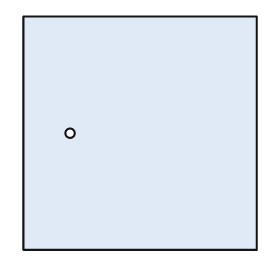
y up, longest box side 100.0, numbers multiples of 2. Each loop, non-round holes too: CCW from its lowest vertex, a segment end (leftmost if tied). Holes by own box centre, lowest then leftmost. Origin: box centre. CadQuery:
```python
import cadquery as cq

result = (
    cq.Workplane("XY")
    .moveTo(-50.0, -50.0)
    .lineTo(50.0, -50.0)
    .lineTo(50.0, 50.0)
    .lineTo(-50.0, 50.0)
    .close()
    .moveTo(-30.0, 0.0)
    .circle(2.0)
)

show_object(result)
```